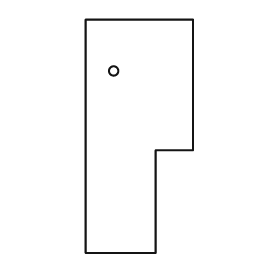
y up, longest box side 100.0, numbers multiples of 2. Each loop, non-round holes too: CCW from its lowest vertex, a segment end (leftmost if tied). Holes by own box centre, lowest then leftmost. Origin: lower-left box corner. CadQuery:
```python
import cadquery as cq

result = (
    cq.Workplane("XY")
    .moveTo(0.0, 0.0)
    .lineTo(30.0, 0.0)
    .lineTo(30.0, 44.0)
    .lineTo(46.0, 44.0)
    .lineTo(46.0, 100.0)
    .lineTo(0.0, 100.0)
    .close()
    .moveTo(12.0, 78.0)
    .circle(2.0)
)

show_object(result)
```